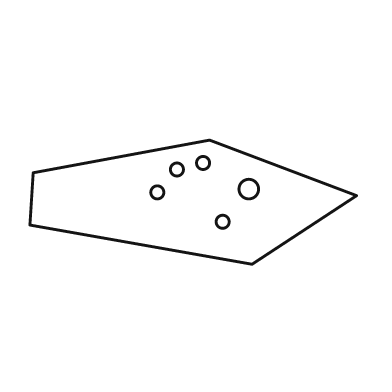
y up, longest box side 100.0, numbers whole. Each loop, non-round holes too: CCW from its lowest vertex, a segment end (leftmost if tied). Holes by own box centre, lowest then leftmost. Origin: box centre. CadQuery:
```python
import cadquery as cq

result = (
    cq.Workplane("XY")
    .moveTo(18.0, -19.0)
    .lineTo(50.0, 2.0)
    .lineTo(5.0, 19.0)
    .lineTo(-49.0, 9.0)
    .lineTo(-50.0, -7.0)
    .close()
    .moveTo(9.0, -6.0)
    .circle(2.0)
    .moveTo(-11.0, 3.0)
    .circle(2.0)
    .moveTo(17.0, 4.0)
    .circle(3.0)
    .moveTo(-5.0, 10.0)
    .circle(2.0)
    .moveTo(3.0, 12.0)
    .circle(2.0)
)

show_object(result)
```